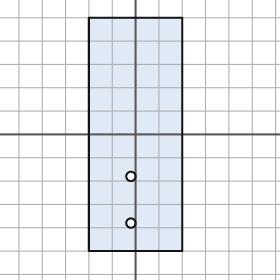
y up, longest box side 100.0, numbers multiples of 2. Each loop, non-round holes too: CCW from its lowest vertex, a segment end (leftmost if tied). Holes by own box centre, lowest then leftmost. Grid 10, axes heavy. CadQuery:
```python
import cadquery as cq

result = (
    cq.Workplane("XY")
    .moveTo(-20.0, -50.0)
    .lineTo(20.0, -50.0)
    .lineTo(20.0, 50.0)
    .lineTo(-20.0, 50.0)
    .close()
    .moveTo(-2.0, -38.0)
    .circle(2.0)
    .moveTo(-2.0, -18.0)
    .circle(2.0)
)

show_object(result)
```